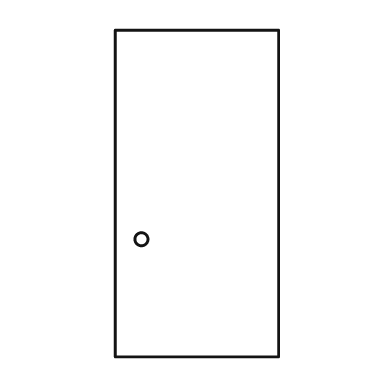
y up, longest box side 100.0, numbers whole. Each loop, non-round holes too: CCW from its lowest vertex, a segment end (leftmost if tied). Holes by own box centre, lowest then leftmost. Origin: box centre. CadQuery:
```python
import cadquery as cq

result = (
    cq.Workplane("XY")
    .moveTo(-25.0, -50.0)
    .lineTo(25.0, -50.0)
    .lineTo(25.0, 50.0)
    .lineTo(-25.0, 50.0)
    .close()
    .moveTo(-17.0, -14.0)
    .circle(2.0)
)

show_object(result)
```